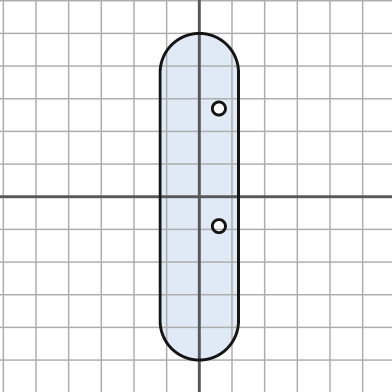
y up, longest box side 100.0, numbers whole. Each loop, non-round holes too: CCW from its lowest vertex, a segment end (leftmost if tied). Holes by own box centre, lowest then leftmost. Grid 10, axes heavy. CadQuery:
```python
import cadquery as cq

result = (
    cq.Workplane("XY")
    .moveTo(-12.0, -38.0)
    .threePointArc((0.0, -50.0), (12.0, -38.0))
    .lineTo(12.0, 38.0)
    .threePointArc((0.0, 50.0), (-12.0, 38.0))
    .close()
    .moveTo(6.0, -9.0)
    .circle(2.0)
    .moveTo(6.0, 27.0)
    .circle(2.0)
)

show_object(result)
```